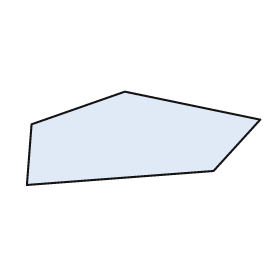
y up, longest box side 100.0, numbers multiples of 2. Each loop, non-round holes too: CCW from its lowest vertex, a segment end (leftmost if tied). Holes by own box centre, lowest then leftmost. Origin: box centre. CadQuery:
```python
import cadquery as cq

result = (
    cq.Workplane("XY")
    .moveTo(-50.0, -20.0)
    .lineTo(30.0, -14.0)
    .lineTo(50.0, 8.0)
    .lineTo(-8.0, 20.0)
    .lineTo(-48.0, 6.0)
    .close()
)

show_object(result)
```